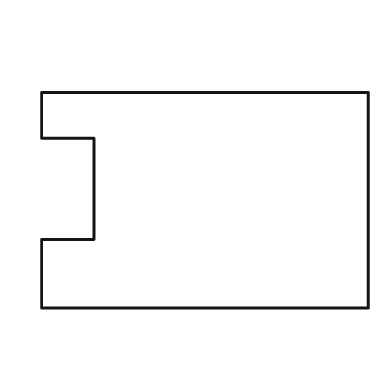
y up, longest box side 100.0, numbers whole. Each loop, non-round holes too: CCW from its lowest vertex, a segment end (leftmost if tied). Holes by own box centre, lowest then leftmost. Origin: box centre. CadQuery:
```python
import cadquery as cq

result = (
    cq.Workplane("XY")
    .moveTo(-50.0, -33.0)
    .lineTo(50.0, -33.0)
    .lineTo(50.0, 33.0)
    .lineTo(-50.0, 33.0)
    .lineTo(-50.0, 19.0)
    .lineTo(-34.0, 19.0)
    .lineTo(-34.0, -12.0)
    .lineTo(-50.0, -12.0)
    .close()
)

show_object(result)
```